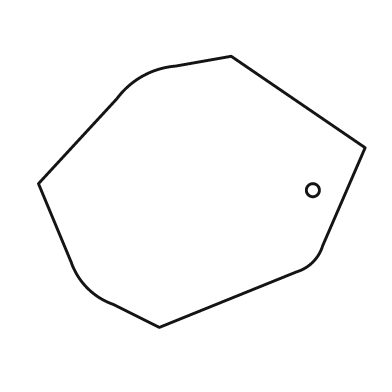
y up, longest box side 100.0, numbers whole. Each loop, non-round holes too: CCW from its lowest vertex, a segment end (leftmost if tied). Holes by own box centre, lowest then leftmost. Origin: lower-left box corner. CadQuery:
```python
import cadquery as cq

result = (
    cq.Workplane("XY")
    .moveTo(37.0, 0.0)
    .lineTo(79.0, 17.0)
    .threePointArc((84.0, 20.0), (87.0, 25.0))
    .lineTo(100.0, 55.0)
    .lineTo(59.0, 83.0)
    .lineTo(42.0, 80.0)
    .threePointArc((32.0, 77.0), (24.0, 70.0))
    .lineTo(0.0, 44.0)
    .lineTo(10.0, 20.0)
    .threePointArc((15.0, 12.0), (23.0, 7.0))
    .close()
    .moveTo(84.0, 42.0)
    .circle(2.0)
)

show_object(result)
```